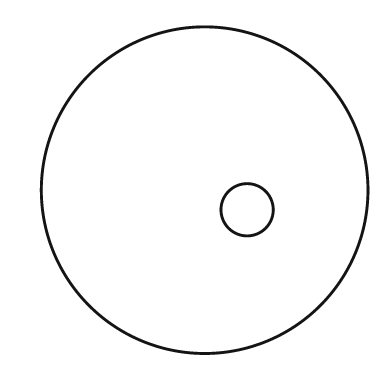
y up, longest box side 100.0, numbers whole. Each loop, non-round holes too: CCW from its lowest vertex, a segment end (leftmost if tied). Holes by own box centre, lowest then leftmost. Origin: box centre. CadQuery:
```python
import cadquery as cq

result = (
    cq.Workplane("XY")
    .moveTo(0.0, 0.0)
    .circle(50.0)
    .moveTo(13.0, -6.0)
    .circle(8.0)
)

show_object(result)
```